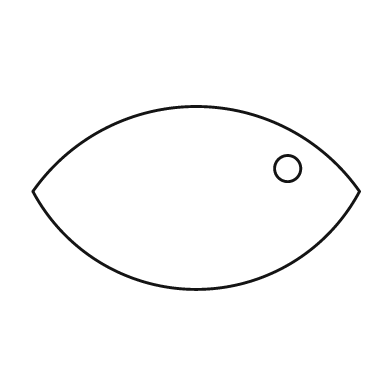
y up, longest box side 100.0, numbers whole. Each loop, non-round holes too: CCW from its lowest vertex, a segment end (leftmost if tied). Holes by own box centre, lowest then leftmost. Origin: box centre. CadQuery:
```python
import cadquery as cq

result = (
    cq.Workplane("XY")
    .moveTo(-50.0, 2.0)
    .threePointArc((0.0, -28.0), (50.0, 2.0))
    .threePointArc((0.0, 28.0), (-50.0, 2.0))
    .close()
    .moveTo(28.0, 9.0)
    .circle(4.0)
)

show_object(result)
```